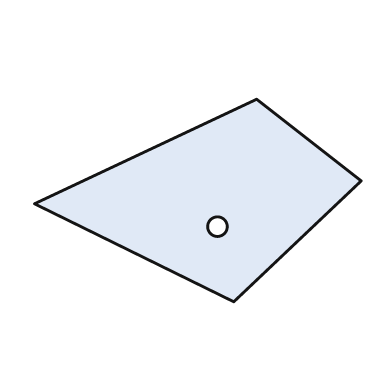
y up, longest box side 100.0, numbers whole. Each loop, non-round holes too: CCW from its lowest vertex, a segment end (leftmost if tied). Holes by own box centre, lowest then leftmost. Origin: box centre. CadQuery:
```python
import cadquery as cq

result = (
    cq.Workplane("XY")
    .moveTo(11.0, -31.0)
    .lineTo(50.0, 6.0)
    .lineTo(18.0, 31.0)
    .lineTo(-50.0, -1.0)
    .close()
    .moveTo(6.0, -8.0)
    .circle(3.0)
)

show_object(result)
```